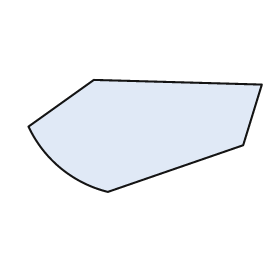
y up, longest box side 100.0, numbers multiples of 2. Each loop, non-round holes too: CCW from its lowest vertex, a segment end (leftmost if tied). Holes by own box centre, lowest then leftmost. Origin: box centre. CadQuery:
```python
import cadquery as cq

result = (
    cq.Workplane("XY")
    .moveTo(-16.0, -24.0)
    .lineTo(42.0, -4.0)
    .lineTo(50.0, 22.0)
    .lineTo(-22.0, 24.0)
    .lineTo(-50.0, 4.0)
    .threePointArc((-36.0, -14.0), (-16.0, -24.0))
    .close()
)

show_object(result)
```